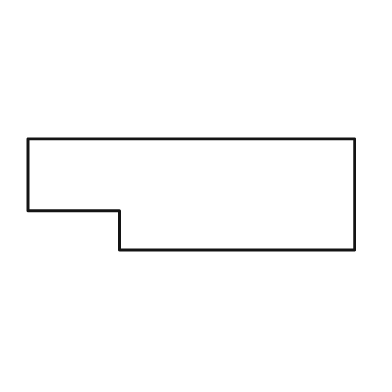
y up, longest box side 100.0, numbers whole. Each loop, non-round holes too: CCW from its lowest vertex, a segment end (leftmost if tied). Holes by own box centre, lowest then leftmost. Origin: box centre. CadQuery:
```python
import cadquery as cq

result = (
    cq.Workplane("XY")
    .moveTo(-22.0, -17.0)
    .lineTo(50.0, -17.0)
    .lineTo(50.0, 17.0)
    .lineTo(-50.0, 17.0)
    .lineTo(-50.0, -5.0)
    .lineTo(-22.0, -5.0)
    .close()
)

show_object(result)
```